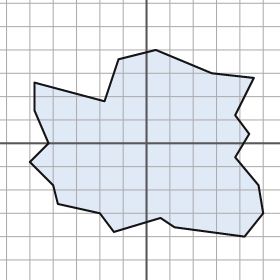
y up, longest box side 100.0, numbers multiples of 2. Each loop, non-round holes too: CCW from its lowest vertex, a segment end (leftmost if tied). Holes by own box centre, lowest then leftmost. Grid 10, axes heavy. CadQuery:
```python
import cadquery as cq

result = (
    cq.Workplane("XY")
    .moveTo(42.0, -40.0)
    .lineTo(50.0, -30.0)
    .lineTo(48.0, -18.0)
    .lineTo(38.0, -6.0)
    .lineTo(44.0, 4.0)
    .lineTo(38.0, 12.0)
    .lineTo(46.0, 28.0)
    .lineTo(28.0, 30.0)
    .lineTo(4.0, 40.0)
    .lineTo(-12.0, 36.0)
    .lineTo(-18.0, 18.0)
    .lineTo(-48.0, 26.0)
    .lineTo(-48.0, 14.0)
    .lineTo(-42.0, 0.0)
    .lineTo(-50.0, -8.0)
    .lineTo(-40.0, -18.0)
    .lineTo(-38.0, -26.0)
    .lineTo(-20.0, -30.0)
    .lineTo(-14.0, -38.0)
    .lineTo(6.0, -32.0)
    .lineTo(12.0, -36.0)
    .close()
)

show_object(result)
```